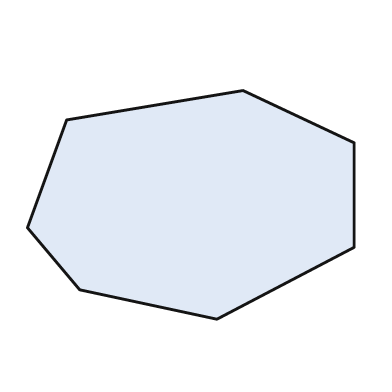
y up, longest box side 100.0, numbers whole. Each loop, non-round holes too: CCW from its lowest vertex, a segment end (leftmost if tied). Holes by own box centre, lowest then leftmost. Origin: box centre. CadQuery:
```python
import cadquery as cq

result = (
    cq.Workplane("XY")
    .moveTo(8.0, -35.0)
    .lineTo(50.0, -13.0)
    .lineTo(50.0, 19.0)
    .lineTo(16.0, 35.0)
    .lineTo(-38.0, 26.0)
    .lineTo(-50.0, -7.0)
    .lineTo(-34.0, -26.0)
    .close()
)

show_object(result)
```